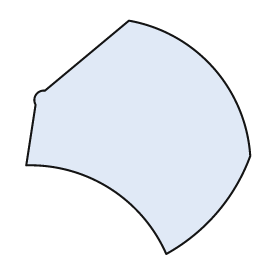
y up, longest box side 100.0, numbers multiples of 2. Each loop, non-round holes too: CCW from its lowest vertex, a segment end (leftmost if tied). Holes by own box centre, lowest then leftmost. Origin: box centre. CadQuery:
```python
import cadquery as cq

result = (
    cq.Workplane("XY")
    .moveTo(12.0, -50.0)
    .threePointArc((34.0, -32.0), (48.0, -8.0))
    .threePointArc((32.0, 30.0), (-4.0, 50.0))
    .lineTo(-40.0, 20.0)
    .threePointArc((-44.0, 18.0), (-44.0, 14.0))
    .lineTo(-48.0, -12.0)
    .threePointArc((-12.0, -22.0), (12.0, -50.0))
    .close()
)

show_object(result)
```